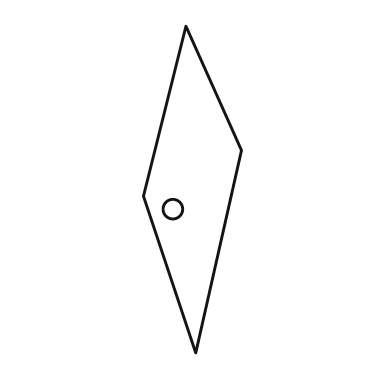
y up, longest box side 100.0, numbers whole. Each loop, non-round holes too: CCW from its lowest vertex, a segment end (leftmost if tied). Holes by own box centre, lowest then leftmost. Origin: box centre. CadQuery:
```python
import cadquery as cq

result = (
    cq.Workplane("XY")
    .moveTo(1.0, -50.0)
    .lineTo(15.0, 12.0)
    .lineTo(-2.0, 50.0)
    .lineTo(-15.0, -2.0)
    .close()
    .moveTo(-6.0, -6.0)
    .circle(3.0)
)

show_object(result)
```